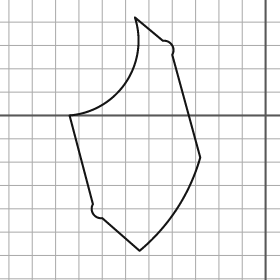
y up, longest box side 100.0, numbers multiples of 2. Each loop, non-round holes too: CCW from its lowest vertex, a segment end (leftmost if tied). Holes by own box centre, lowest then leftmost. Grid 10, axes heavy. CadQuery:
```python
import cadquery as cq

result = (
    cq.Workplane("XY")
    .moveTo(-54.0, -58.0)
    .threePointArc((-38.0, -40.0), (-28.0, -18.0))
    .lineTo(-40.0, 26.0)
    .threePointArc((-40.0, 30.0), (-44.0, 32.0))
    .lineTo(-56.0, 42.0)
    .threePointArc((-60.0, 14.0), (-84.0, 0.0))
    .lineTo(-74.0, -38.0)
    .threePointArc((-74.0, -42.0), (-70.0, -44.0))
    .close()
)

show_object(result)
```